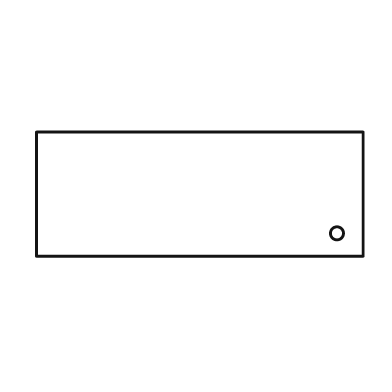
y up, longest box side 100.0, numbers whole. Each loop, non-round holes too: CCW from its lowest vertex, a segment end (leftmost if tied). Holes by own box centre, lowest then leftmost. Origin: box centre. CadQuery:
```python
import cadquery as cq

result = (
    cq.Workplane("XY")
    .moveTo(-50.0, -19.0)
    .lineTo(50.0, -19.0)
    .lineTo(50.0, 19.0)
    .lineTo(-50.0, 19.0)
    .close()
    .moveTo(42.0, -12.0)
    .circle(2.0)
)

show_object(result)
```